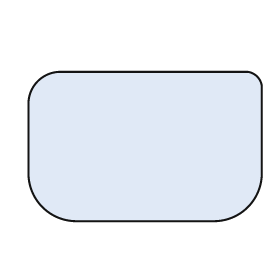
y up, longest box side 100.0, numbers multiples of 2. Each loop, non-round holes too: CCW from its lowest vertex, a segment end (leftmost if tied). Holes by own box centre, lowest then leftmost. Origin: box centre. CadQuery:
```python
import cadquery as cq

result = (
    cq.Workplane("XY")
    .moveTo(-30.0, -32.0)
    .lineTo(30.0, -32.0)
    .threePointArc((44.0, -26.0), (50.0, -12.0))
    .lineTo(50.0, 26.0)
    .threePointArc((48.0, 30.0), (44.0, 32.0))
    .lineTo(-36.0, 32.0)
    .threePointArc((-46.0, 28.0), (-50.0, 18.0))
    .lineTo(-50.0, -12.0)
    .threePointArc((-44.0, -26.0), (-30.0, -32.0))
    .close()
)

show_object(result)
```